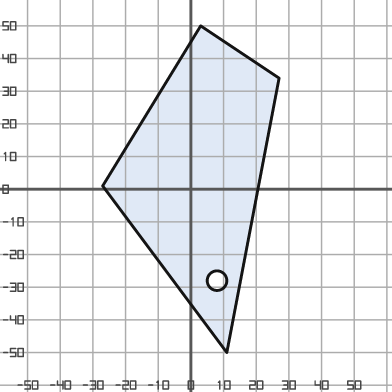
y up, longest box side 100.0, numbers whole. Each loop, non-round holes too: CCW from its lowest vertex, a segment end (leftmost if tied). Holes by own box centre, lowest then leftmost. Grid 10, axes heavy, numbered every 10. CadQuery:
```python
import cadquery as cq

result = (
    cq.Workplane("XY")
    .moveTo(11.0, -50.0)
    .lineTo(27.0, 34.0)
    .lineTo(3.0, 50.0)
    .lineTo(-27.0, 1.0)
    .close()
    .moveTo(8.0, -28.0)
    .circle(3.0)
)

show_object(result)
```